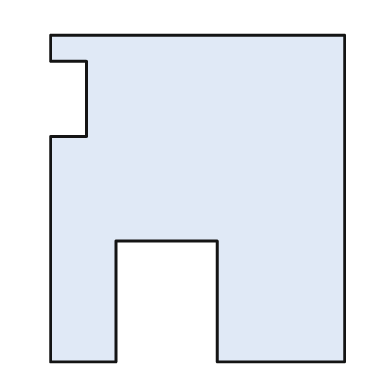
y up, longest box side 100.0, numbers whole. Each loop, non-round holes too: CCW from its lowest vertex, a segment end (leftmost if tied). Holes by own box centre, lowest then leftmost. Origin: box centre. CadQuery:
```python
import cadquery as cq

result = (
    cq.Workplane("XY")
    .moveTo(-45.0, -50.0)
    .lineTo(-25.0, -50.0)
    .lineTo(-25.0, -13.0)
    .lineTo(6.0, -13.0)
    .lineTo(6.0, -50.0)
    .lineTo(45.0, -50.0)
    .lineTo(45.0, 50.0)
    .lineTo(-45.0, 50.0)
    .lineTo(-45.0, 42.0)
    .lineTo(-34.0, 42.0)
    .lineTo(-34.0, 19.0)
    .lineTo(-45.0, 19.0)
    .close()
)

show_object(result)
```